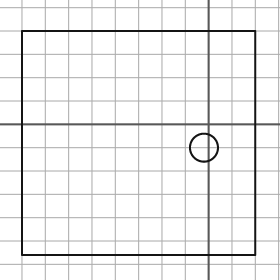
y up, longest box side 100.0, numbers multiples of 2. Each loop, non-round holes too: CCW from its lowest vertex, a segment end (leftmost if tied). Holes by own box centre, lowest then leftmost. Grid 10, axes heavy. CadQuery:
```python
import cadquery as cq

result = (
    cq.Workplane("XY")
    .moveTo(-80.0, -56.0)
    .lineTo(20.0, -56.0)
    .lineTo(20.0, 40.0)
    .lineTo(-80.0, 40.0)
    .close()
    .moveTo(-2.0, -10.0)
    .circle(6.0)
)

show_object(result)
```